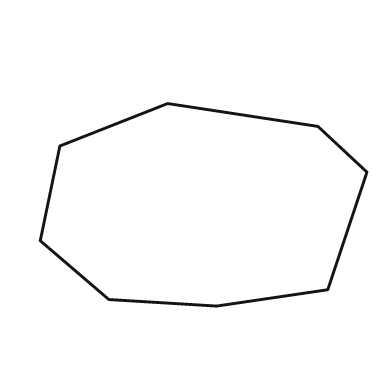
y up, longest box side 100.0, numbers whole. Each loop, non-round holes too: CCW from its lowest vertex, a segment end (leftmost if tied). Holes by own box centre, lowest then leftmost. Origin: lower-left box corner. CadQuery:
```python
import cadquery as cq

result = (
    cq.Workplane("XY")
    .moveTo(54.0, 0.0)
    .lineTo(88.0, 5.0)
    .lineTo(100.0, 41.0)
    .lineTo(85.0, 55.0)
    .lineTo(39.0, 62.0)
    .lineTo(6.0, 49.0)
    .lineTo(0.0, 20.0)
    .lineTo(21.0, 2.0)
    .close()
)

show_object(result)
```